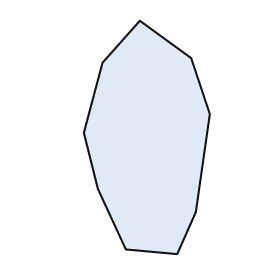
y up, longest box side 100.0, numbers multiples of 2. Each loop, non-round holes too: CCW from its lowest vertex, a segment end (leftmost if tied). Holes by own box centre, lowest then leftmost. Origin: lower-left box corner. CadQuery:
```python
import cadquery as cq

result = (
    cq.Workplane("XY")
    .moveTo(40.0, 0.0)
    .lineTo(48.0, 18.0)
    .lineTo(54.0, 60.0)
    .lineTo(46.0, 84.0)
    .lineTo(24.0, 100.0)
    .lineTo(8.0, 82.0)
    .lineTo(0.0, 52.0)
    .lineTo(6.0, 28.0)
    .lineTo(18.0, 2.0)
    .close()
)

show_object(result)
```